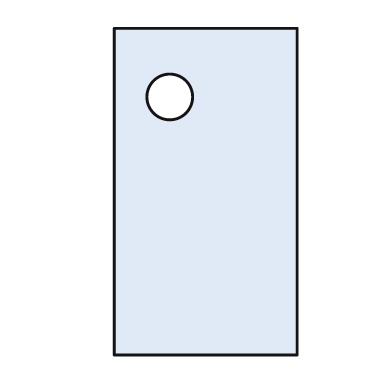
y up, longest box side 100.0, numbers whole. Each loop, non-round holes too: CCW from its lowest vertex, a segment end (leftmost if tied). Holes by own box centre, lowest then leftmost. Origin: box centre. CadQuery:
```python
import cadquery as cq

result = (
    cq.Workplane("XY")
    .moveTo(-28.0, -50.0)
    .lineTo(28.0, -50.0)
    .lineTo(28.0, 50.0)
    .lineTo(-28.0, 50.0)
    .close()
    .moveTo(-11.0, 29.0)
    .circle(7.0)
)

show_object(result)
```